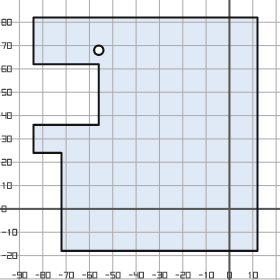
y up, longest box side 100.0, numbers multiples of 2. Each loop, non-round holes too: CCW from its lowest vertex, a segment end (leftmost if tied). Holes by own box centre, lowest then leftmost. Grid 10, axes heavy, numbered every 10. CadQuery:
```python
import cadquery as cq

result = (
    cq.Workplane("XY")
    .moveTo(-72.0, -18.0)
    .lineTo(12.0, -18.0)
    .lineTo(12.0, 82.0)
    .lineTo(-84.0, 82.0)
    .lineTo(-84.0, 62.0)
    .lineTo(-56.0, 62.0)
    .lineTo(-56.0, 36.0)
    .lineTo(-84.0, 36.0)
    .lineTo(-84.0, 24.0)
    .lineTo(-72.0, 24.0)
    .close()
    .moveTo(-56.0, 68.0)
    .circle(2.0)
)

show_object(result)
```